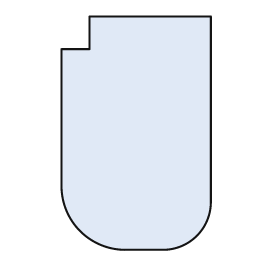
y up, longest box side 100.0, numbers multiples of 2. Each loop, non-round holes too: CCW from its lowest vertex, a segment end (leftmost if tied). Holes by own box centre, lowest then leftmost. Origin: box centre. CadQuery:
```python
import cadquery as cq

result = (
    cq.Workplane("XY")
    .moveTo(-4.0, -50.0)
    .lineTo(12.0, -50.0)
    .threePointArc((26.0, -44.0), (32.0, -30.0))
    .lineTo(32.0, 50.0)
    .lineTo(-20.0, 50.0)
    .lineTo(-20.0, 36.0)
    .lineTo(-32.0, 36.0)
    .lineTo(-32.0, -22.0)
    .threePointArc((-24.0, -42.0), (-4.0, -50.0))
    .close()
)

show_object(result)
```